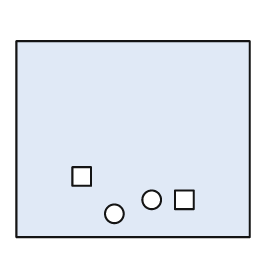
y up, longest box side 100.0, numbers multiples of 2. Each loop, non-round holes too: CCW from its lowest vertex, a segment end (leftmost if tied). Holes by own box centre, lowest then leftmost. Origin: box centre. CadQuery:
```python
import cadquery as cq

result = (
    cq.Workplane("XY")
    .moveTo(-50.0, -42.0)
    .lineTo(50.0, -42.0)
    .lineTo(50.0, 42.0)
    .lineTo(-50.0, 42.0)
    .close()
    .moveTo(-8.0, -32.0)
    .circle(4.0)
    .moveTo(8.0, -26.0)
    .circle(4.0)
    .moveTo(18.0, -30.0)
    .lineTo(26.0, -30.0)
    .lineTo(26.0, -22.0)
    .lineTo(18.0, -22.0)
    .close()
    .moveTo(-26.0, -20.0)
    .lineTo(-18.0, -20.0)
    .lineTo(-18.0, -12.0)
    .lineTo(-26.0, -12.0)
    .close()
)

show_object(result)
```